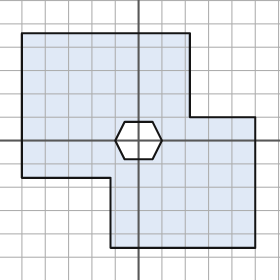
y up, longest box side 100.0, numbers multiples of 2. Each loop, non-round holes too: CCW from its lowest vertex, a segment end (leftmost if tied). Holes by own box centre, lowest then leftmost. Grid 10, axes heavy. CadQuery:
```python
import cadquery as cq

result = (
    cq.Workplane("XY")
    .moveTo(-12.0, -46.0)
    .lineTo(50.0, -46.0)
    .lineTo(50.0, 10.0)
    .lineTo(22.0, 10.0)
    .lineTo(22.0, 46.0)
    .lineTo(-50.0, 46.0)
    .lineTo(-50.0, -16.0)
    .lineTo(-12.0, -16.0)
    .close()
    .moveTo(-6.0, -8.0)
    .lineTo(6.0, -8.0)
    .lineTo(10.0, 0.0)
    .lineTo(6.0, 8.0)
    .lineTo(-6.0, 8.0)
    .lineTo(-10.0, 0.0)
    .close()
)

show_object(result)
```